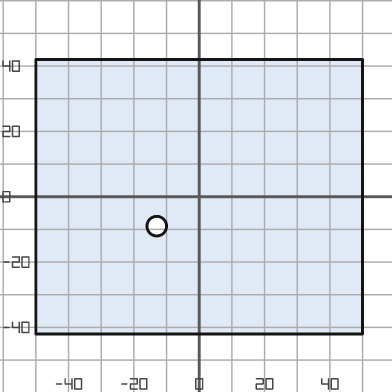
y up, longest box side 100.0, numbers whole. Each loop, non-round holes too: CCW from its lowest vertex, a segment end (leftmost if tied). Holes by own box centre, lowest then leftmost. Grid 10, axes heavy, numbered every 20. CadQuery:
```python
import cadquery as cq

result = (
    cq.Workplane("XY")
    .moveTo(-50.0, -42.0)
    .lineTo(50.0, -42.0)
    .lineTo(50.0, 42.0)
    .lineTo(-50.0, 42.0)
    .close()
    .moveTo(-13.0, -9.0)
    .circle(3.0)
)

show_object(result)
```